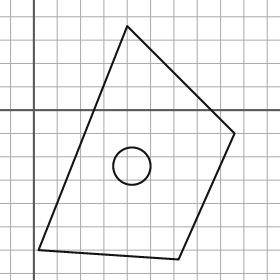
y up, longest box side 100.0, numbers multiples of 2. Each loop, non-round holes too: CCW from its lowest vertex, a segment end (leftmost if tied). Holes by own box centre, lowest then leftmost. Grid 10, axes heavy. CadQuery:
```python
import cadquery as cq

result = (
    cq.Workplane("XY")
    .moveTo(62.0, -64.0)
    .lineTo(86.0, -10.0)
    .lineTo(40.0, 36.0)
    .lineTo(2.0, -60.0)
    .close()
    .moveTo(42.0, -24.0)
    .circle(8.0)
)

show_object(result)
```